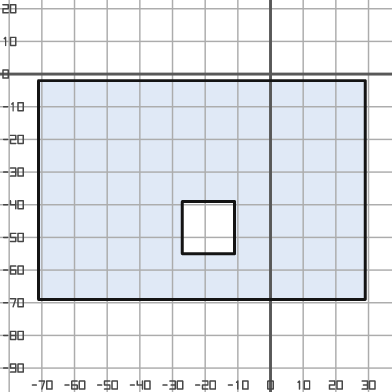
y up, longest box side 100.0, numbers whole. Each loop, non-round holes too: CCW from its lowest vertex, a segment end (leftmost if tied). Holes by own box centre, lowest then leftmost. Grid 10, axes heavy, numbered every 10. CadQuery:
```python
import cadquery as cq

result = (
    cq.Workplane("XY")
    .moveTo(-71.0, -69.0)
    .lineTo(29.0, -69.0)
    .lineTo(29.0, -2.0)
    .lineTo(-71.0, -2.0)
    .close()
    .moveTo(-27.0, -55.0)
    .lineTo(-11.0, -55.0)
    .lineTo(-11.0, -39.0)
    .lineTo(-27.0, -39.0)
    .close()
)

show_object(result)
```